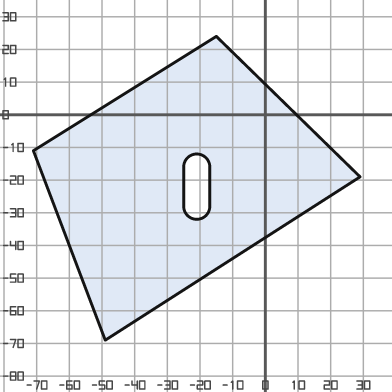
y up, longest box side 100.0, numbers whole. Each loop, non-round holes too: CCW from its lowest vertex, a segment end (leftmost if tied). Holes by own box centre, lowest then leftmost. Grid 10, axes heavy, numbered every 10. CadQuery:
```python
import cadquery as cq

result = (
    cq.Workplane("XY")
    .moveTo(-49.0, -69.0)
    .lineTo(29.0, -19.0)
    .lineTo(-15.0, 24.0)
    .lineTo(-71.0, -11.0)
    .close()
    .moveTo(-25.0, -28.0)
    .threePointArc((-21.0, -32.0), (-17.0, -28.0))
    .lineTo(-17.0, -16.0)
    .threePointArc((-21.0, -12.0), (-25.0, -16.0))
    .close()
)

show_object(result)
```